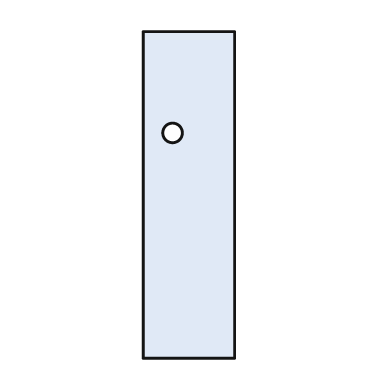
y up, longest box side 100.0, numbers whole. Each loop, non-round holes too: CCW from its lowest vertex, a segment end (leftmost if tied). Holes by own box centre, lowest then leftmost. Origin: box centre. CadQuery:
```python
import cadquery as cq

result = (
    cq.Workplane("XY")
    .moveTo(-14.0, -50.0)
    .lineTo(14.0, -50.0)
    .lineTo(14.0, 50.0)
    .lineTo(-14.0, 50.0)
    .close()
    .moveTo(-5.0, 19.0)
    .circle(3.0)
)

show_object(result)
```